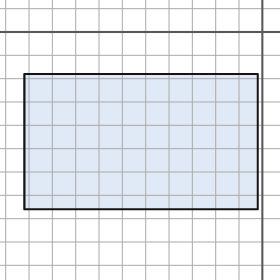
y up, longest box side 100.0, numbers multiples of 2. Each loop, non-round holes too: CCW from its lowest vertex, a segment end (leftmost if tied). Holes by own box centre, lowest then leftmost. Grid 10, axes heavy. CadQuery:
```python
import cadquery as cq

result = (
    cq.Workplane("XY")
    .moveTo(-102.0, -76.0)
    .lineTo(-2.0, -76.0)
    .lineTo(-2.0, -18.0)
    .lineTo(-102.0, -18.0)
    .close()
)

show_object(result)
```